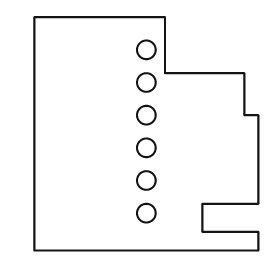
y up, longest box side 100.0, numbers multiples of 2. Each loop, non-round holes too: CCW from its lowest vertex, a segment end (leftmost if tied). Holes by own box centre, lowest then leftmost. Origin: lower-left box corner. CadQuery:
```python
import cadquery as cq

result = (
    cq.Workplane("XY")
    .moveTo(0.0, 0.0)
    .lineTo(96.0, 0.0)
    .lineTo(96.0, 8.0)
    .lineTo(72.0, 8.0)
    .lineTo(72.0, 20.0)
    .lineTo(96.0, 20.0)
    .lineTo(96.0, 58.0)
    .lineTo(90.0, 58.0)
    .lineTo(90.0, 76.0)
    .lineTo(56.0, 76.0)
    .lineTo(56.0, 100.0)
    .lineTo(0.0, 100.0)
    .close()
    .moveTo(48.0, 16.0)
    .circle(4.0)
    .moveTo(48.0, 30.0)
    .circle(4.0)
    .moveTo(48.0, 44.0)
    .circle(4.0)
    .moveTo(48.0, 58.0)
    .circle(4.0)
    .moveTo(48.0, 72.0)
    .circle(4.0)
    .moveTo(48.0, 86.0)
    .circle(4.0)
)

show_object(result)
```